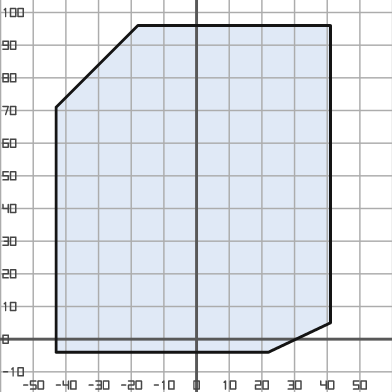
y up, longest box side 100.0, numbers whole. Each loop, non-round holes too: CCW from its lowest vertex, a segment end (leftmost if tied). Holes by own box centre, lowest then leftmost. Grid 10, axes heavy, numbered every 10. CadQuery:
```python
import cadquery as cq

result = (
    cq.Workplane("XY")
    .moveTo(-43.0, -4.0)
    .lineTo(22.0, -4.0)
    .lineTo(41.0, 5.0)
    .lineTo(41.0, 96.0)
    .lineTo(-18.0, 96.0)
    .lineTo(-43.0, 71.0)
    .close()
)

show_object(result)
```